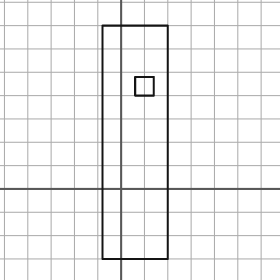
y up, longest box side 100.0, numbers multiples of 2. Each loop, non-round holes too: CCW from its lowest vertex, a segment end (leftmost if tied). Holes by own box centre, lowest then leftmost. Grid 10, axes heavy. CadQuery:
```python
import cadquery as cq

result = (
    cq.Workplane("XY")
    .moveTo(-8.0, -30.0)
    .lineTo(20.0, -30.0)
    .lineTo(20.0, 70.0)
    .lineTo(-8.0, 70.0)
    .close()
    .moveTo(6.0, 40.0)
    .lineTo(14.0, 40.0)
    .lineTo(14.0, 48.0)
    .lineTo(6.0, 48.0)
    .close()
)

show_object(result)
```